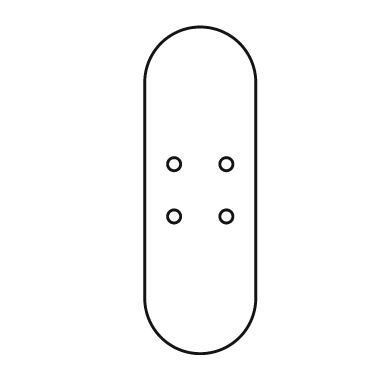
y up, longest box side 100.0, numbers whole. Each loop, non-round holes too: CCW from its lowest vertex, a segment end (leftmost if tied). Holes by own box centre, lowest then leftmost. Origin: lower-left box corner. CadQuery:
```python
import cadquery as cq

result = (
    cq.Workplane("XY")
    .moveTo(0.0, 17.0)
    .threePointArc((17.0, 0.0), (34.0, 17.0))
    .lineTo(34.0, 83.0)
    .threePointArc((17.0, 100.0), (0.0, 83.0))
    .close()
    .moveTo(9.0, 42.0)
    .circle(2.0)
    .moveTo(25.0, 42.0)
    .circle(2.0)
    .moveTo(9.0, 58.0)
    .circle(2.0)
    .moveTo(25.0, 58.0)
    .circle(2.0)
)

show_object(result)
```